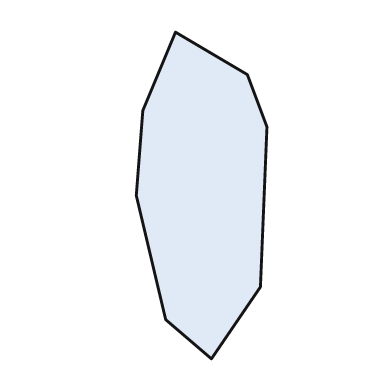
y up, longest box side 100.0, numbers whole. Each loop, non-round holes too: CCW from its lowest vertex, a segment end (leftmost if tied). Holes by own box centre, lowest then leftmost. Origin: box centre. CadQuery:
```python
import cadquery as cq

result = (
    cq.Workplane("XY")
    .moveTo(3.0, -50.0)
    .lineTo(18.0, -28.0)
    .lineTo(20.0, 21.0)
    .lineTo(14.0, 37.0)
    .lineTo(-8.0, 50.0)
    .lineTo(-18.0, 26.0)
    .lineTo(-20.0, 0.0)
    .lineTo(-11.0, -38.0)
    .close()
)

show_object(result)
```